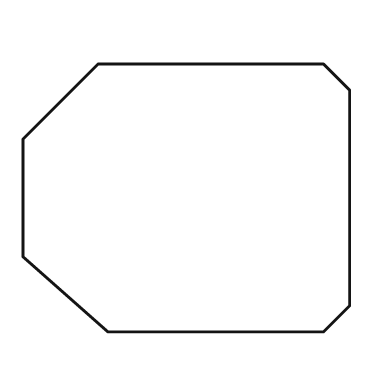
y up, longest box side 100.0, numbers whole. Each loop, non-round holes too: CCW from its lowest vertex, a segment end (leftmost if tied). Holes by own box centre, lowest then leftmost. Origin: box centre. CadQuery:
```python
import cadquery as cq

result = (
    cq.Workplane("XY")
    .moveTo(-24.0, -41.0)
    .lineTo(42.0, -41.0)
    .lineTo(50.0, -33.0)
    .lineTo(50.0, 33.0)
    .lineTo(42.0, 41.0)
    .lineTo(-27.0, 41.0)
    .lineTo(-50.0, 18.0)
    .lineTo(-50.0, -18.0)
    .close()
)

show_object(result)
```